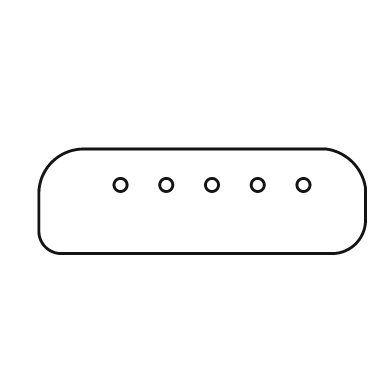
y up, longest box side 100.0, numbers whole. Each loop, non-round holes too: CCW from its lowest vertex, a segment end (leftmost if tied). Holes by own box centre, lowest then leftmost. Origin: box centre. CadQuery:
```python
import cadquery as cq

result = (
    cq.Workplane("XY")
    .moveTo(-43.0, -16.0)
    .lineTo(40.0, -16.0)
    .threePointArc((47.0, -13.0), (50.0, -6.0))
    .lineTo(50.0, 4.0)
    .threePointArc((46.0, 12.0), (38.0, 16.0))
    .lineTo(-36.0, 16.0)
    .threePointArc((-46.0, 12.0), (-50.0, 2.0))
    .lineTo(-50.0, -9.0)
    .threePointArc((-48.0, -14.0), (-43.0, -16.0))
    .close()
    .moveTo(-25.0, 5.0)
    .circle(2.0)
    .moveTo(-11.0, 5.0)
    .circle(2.0)
    .moveTo(3.0, 5.0)
    .circle(2.0)
    .moveTo(17.0, 5.0)
    .circle(2.0)
    .moveTo(31.0, 5.0)
    .circle(2.0)
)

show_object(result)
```